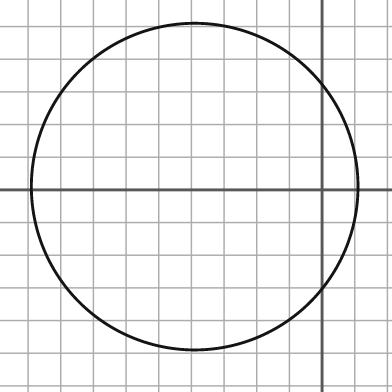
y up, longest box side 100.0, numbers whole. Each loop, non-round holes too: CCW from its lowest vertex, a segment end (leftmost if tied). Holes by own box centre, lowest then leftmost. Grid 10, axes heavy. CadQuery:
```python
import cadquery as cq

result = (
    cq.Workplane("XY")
    .moveTo(-39.0, 1.0)
    .circle(50.0)
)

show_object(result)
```